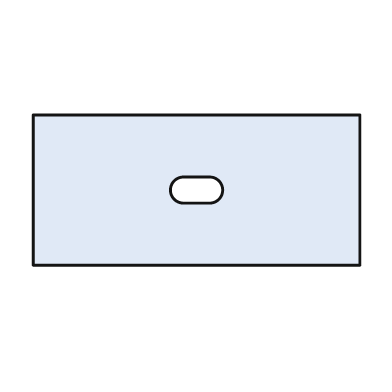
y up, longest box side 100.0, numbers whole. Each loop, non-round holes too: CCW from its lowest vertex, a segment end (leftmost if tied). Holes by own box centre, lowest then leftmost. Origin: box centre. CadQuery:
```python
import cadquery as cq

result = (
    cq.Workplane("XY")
    .moveTo(-50.0, -23.0)
    .lineTo(50.0, -23.0)
    .lineTo(50.0, 23.0)
    .lineTo(-50.0, 23.0)
    .close()
    .moveTo(-4.0, -4.0)
    .lineTo(4.0, -4.0)
    .threePointArc((8.0, 0.0), (4.0, 4.0))
    .lineTo(-4.0, 4.0)
    .threePointArc((-8.0, 0.0), (-4.0, -4.0))
    .close()
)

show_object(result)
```